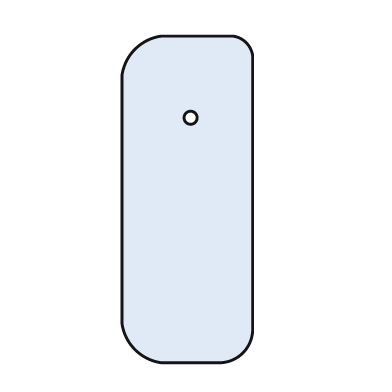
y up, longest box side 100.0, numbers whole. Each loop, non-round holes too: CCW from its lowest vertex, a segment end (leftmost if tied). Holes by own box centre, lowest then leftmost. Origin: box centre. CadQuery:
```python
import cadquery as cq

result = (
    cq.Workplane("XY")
    .moveTo(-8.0, -50.0)
    .lineTo(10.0, -50.0)
    .threePointArc((17.0, -47.0), (20.0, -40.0))
    .lineTo(20.0, 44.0)
    .threePointArc((18.0, 48.0), (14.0, 50.0))
    .lineTo(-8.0, 50.0)
    .threePointArc((-16.0, 46.0), (-20.0, 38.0))
    .lineTo(-20.0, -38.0)
    .threePointArc((-16.0, -46.0), (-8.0, -50.0))
    .close()
    .moveTo(1.0, 25.0)
    .circle(2.0)
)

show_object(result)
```